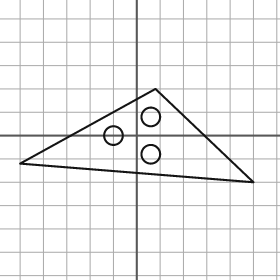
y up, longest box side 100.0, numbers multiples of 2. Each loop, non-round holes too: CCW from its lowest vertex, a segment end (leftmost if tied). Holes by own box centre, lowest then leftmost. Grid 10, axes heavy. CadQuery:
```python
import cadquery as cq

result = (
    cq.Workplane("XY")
    .moveTo(50.0, -20.0)
    .lineTo(8.0, 20.0)
    .lineTo(-50.0, -12.0)
    .close()
    .moveTo(6.0, -8.0)
    .circle(4.0)
    .moveTo(-10.0, 0.0)
    .circle(4.0)
    .moveTo(6.0, 8.0)
    .circle(4.0)
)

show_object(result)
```